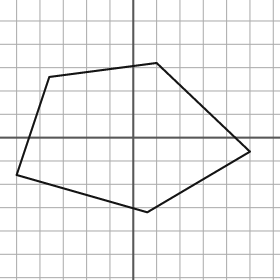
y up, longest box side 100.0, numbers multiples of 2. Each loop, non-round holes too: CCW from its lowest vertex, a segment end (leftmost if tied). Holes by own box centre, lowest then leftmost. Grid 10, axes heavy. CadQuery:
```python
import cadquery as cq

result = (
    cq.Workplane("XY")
    .moveTo(6.0, -32.0)
    .lineTo(50.0, -6.0)
    .lineTo(10.0, 32.0)
    .lineTo(-36.0, 26.0)
    .lineTo(-50.0, -16.0)
    .close()
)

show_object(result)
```